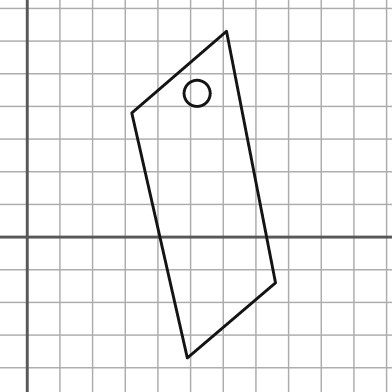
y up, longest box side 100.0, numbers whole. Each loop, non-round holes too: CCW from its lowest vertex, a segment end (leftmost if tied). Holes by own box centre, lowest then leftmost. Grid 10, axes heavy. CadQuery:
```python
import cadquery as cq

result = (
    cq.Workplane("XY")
    .moveTo(49.0, -37.0)
    .lineTo(76.0, -14.0)
    .lineTo(61.0, 63.0)
    .lineTo(32.0, 38.0)
    .close()
    .moveTo(52.0, 44.0)
    .circle(4.0)
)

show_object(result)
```